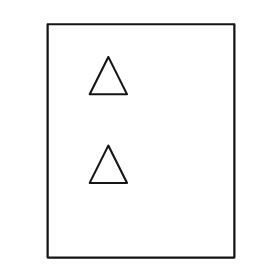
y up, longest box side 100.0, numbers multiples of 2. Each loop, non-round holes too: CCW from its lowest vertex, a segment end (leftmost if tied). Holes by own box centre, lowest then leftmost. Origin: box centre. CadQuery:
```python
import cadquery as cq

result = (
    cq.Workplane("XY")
    .moveTo(-40.0, -50.0)
    .lineTo(40.0, -50.0)
    .lineTo(40.0, 50.0)
    .lineTo(-40.0, 50.0)
    .close()
    .moveTo(-22.0, -18.0)
    .lineTo(-6.0, -18.0)
    .lineTo(-14.0, -2.0)
    .close()
    .moveTo(-22.0, 20.0)
    .lineTo(-6.0, 20.0)
    .lineTo(-14.0, 36.0)
    .close()
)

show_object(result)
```